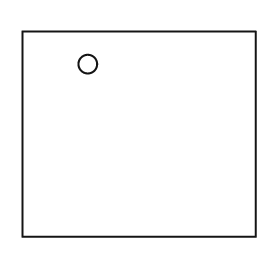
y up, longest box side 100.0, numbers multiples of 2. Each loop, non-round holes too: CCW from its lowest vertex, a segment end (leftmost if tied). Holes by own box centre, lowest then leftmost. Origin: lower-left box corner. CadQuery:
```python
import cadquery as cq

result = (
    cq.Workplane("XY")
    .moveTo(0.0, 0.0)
    .lineTo(100.0, 0.0)
    .lineTo(100.0, 88.0)
    .lineTo(0.0, 88.0)
    .close()
    .moveTo(28.0, 74.0)
    .circle(4.0)
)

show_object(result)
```